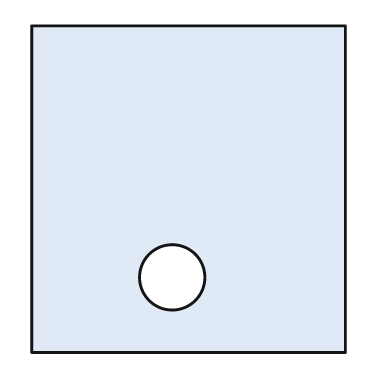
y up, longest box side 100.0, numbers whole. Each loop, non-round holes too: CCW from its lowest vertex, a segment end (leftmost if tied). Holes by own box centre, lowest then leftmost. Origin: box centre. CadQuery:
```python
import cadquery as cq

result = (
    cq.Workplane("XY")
    .moveTo(-48.0, -50.0)
    .lineTo(48.0, -50.0)
    .lineTo(48.0, 50.0)
    .lineTo(-48.0, 50.0)
    .close()
    .moveTo(-5.0, -27.0)
    .circle(10.0)
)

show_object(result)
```